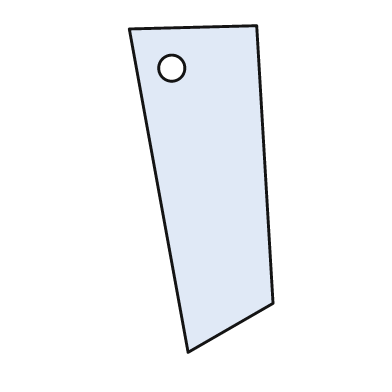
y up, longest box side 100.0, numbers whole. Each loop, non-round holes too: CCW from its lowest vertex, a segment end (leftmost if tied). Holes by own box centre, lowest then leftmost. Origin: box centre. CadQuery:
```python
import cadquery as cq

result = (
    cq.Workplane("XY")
    .moveTo(-4.0, -50.0)
    .lineTo(22.0, -35.0)
    .lineTo(17.0, 50.0)
    .lineTo(-22.0, 49.0)
    .close()
    .moveTo(-9.0, 37.0)
    .circle(4.0)
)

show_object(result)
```